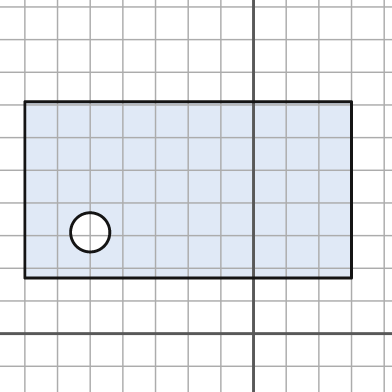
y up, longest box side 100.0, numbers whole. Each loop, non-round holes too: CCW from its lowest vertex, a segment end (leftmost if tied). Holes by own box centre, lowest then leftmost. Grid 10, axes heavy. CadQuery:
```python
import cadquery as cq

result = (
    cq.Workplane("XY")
    .moveTo(-70.0, 17.0)
    .lineTo(30.0, 17.0)
    .lineTo(30.0, 71.0)
    .lineTo(-70.0, 71.0)
    .close()
    .moveTo(-50.0, 31.0)
    .circle(6.0)
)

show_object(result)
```